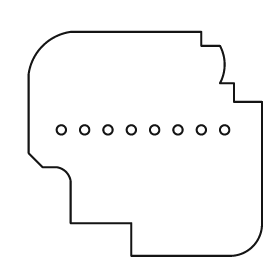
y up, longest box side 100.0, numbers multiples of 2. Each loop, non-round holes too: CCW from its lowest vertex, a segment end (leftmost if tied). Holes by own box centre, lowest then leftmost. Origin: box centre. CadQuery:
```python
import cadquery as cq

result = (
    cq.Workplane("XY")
    .moveTo(-6.0, -48.0)
    .lineTo(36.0, -48.0)
    .threePointArc((46.0, -44.0), (50.0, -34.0))
    .lineTo(50.0, 18.0)
    .lineTo(38.0, 18.0)
    .lineTo(38.0, 26.0)
    .lineTo(32.0, 26.0)
    .threePointArc((34.0, 34.0), (32.0, 42.0))
    .lineTo(24.0, 42.0)
    .lineTo(24.0, 48.0)
    .lineTo(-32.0, 48.0)
    .threePointArc((-44.0, 42.0), (-50.0, 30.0))
    .lineTo(-50.0, -4.0)
    .lineTo(-44.0, -10.0)
    .lineTo(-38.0, -10.0)
    .threePointArc((-34.0, -12.0), (-32.0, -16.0))
    .lineTo(-32.0, -34.0)
    .lineTo(-6.0, -34.0)
    .close()
    .moveTo(-36.0, 6.0)
    .circle(2.0)
    .moveTo(-26.0, 6.0)
    .circle(2.0)
    .moveTo(-16.0, 6.0)
    .circle(2.0)
    .moveTo(-6.0, 6.0)
    .circle(2.0)
    .moveTo(4.0, 6.0)
    .circle(2.0)
    .moveTo(14.0, 6.0)
    .circle(2.0)
    .moveTo(24.0, 6.0)
    .circle(2.0)
    .moveTo(34.0, 6.0)
    .circle(2.0)
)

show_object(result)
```